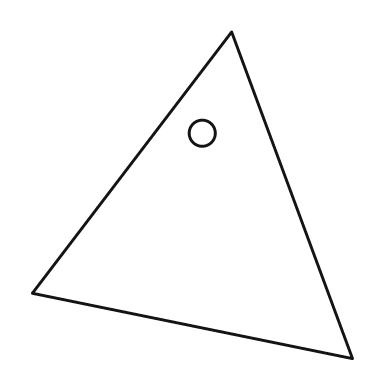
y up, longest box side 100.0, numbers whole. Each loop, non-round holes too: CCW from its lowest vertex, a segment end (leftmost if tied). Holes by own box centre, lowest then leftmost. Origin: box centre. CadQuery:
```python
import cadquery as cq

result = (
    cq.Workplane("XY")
    .moveTo(49.0, -50.0)
    .lineTo(12.0, 50.0)
    .lineTo(-49.0, -30.0)
    .close()
    .moveTo(3.0, 19.0)
    .circle(4.0)
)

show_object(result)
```